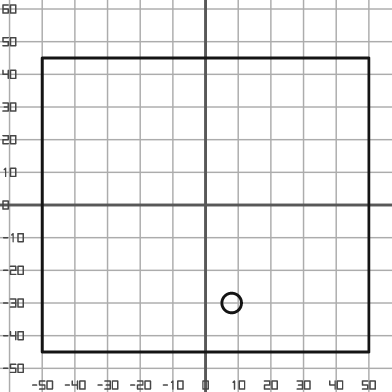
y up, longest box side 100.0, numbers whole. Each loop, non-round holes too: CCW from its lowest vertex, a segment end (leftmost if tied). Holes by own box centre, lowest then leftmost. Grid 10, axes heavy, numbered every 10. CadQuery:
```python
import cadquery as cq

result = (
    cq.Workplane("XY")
    .moveTo(-50.0, -45.0)
    .lineTo(50.0, -45.0)
    .lineTo(50.0, 45.0)
    .lineTo(-50.0, 45.0)
    .close()
    .moveTo(8.0, -30.0)
    .circle(3.0)
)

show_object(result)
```